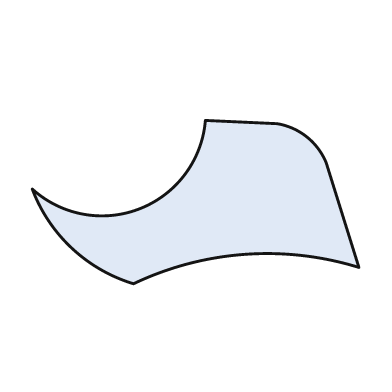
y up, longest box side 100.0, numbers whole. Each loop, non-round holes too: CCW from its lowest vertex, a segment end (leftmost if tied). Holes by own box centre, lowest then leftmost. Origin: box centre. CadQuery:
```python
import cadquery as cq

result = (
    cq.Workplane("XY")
    .moveTo(-19.0, -25.0)
    .threePointArc((15.0, -16.0), (50.0, -20.0))
    .lineTo(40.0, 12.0)
    .threePointArc((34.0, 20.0), (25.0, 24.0))
    .lineTo(3.0, 25.0)
    .threePointArc((-17.0, -2.0), (-50.0, 4.0))
    .threePointArc((-38.0, -14.0), (-19.0, -25.0))
    .close()
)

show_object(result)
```